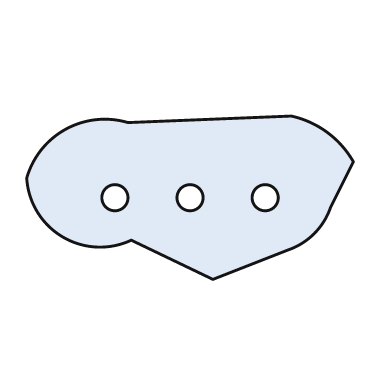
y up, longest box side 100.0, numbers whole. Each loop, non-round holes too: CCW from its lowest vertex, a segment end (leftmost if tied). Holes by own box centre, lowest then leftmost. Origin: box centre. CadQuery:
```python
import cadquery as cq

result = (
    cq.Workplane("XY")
    .moveTo(7.0, -25.0)
    .lineTo(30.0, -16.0)
    .threePointArc((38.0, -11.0), (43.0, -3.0))
    .lineTo(50.0, 11.0)
    .threePointArc((42.0, 20.0), (31.0, 25.0))
    .lineTo(-19.0, 23.0)
    .threePointArc((-38.0, 21.0), (-50.0, 6.0))
    .threePointArc((-39.0, -12.0), (-18.0, -13.0))
    .close()
    .moveTo(-23.0, 0.0)
    .circle(4.0)
    .moveTo(0.0, 0.0)
    .circle(4.0)
    .moveTo(23.0, 0.0)
    .circle(4.0)
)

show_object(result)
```